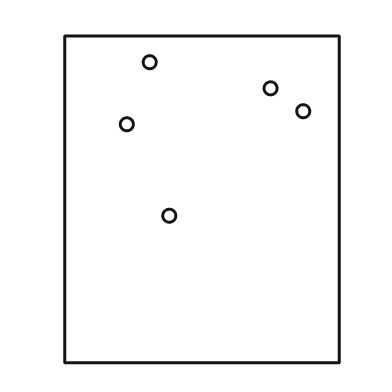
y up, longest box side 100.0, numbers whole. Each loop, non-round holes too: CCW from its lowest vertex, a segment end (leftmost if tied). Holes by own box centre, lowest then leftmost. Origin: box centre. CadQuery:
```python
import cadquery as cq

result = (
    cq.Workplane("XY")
    .moveTo(-42.0, -50.0)
    .lineTo(42.0, -50.0)
    .lineTo(42.0, 50.0)
    .lineTo(-42.0, 50.0)
    .close()
    .moveTo(-10.0, -5.0)
    .circle(2.0)
    .moveTo(-23.0, 23.0)
    .circle(2.0)
    .moveTo(31.0, 27.0)
    .circle(2.0)
    .moveTo(21.0, 34.0)
    .circle(2.0)
    .moveTo(-16.0, 42.0)
    .circle(2.0)
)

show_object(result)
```